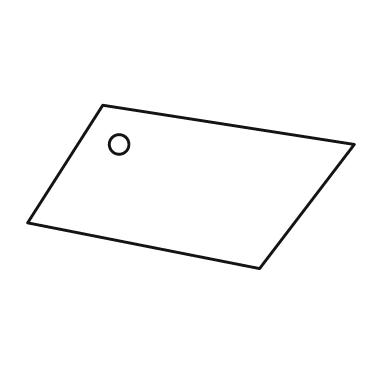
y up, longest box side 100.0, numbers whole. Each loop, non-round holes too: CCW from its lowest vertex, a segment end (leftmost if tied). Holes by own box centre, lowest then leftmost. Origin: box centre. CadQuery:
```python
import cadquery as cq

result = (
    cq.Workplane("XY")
    .moveTo(21.0, -25.0)
    .lineTo(50.0, 13.0)
    .lineTo(-27.0, 25.0)
    .lineTo(-50.0, -11.0)
    .close()
    .moveTo(-22.0, 13.0)
    .circle(3.0)
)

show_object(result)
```